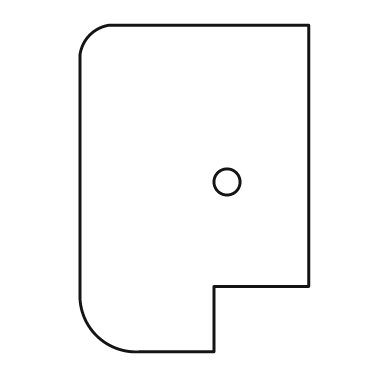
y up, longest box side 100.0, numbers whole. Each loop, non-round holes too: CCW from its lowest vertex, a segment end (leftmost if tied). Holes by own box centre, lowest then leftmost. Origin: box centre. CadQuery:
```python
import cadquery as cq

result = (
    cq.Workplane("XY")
    .moveTo(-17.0, -50.0)
    .lineTo(6.0, -50.0)
    .lineTo(6.0, -30.0)
    .lineTo(35.0, -30.0)
    .lineTo(35.0, 50.0)
    .lineTo(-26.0, 50.0)
    .threePointArc((-32.0, 47.0), (-35.0, 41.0))
    .lineTo(-35.0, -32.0)
    .threePointArc((-30.0, -45.0), (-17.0, -50.0))
    .close()
    .moveTo(10.0, 2.0)
    .circle(4.0)
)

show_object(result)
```